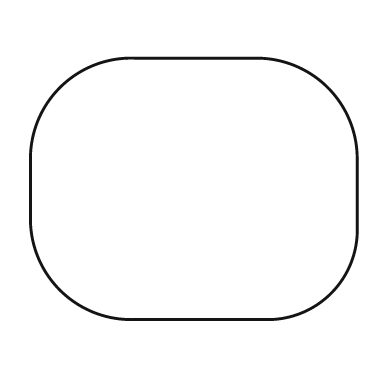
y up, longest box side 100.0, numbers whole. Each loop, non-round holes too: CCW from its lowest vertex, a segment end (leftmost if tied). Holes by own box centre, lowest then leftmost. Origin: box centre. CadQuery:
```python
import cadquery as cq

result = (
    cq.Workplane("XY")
    .moveTo(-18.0, -40.0)
    .lineTo(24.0, -40.0)
    .threePointArc((42.0, -32.0), (50.0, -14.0))
    .lineTo(50.0, 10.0)
    .threePointArc((41.0, 31.0), (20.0, 40.0))
    .lineTo(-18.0, 40.0)
    .threePointArc((-41.0, 31.0), (-50.0, 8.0))
    .lineTo(-50.0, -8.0)
    .threePointArc((-41.0, -31.0), (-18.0, -40.0))
    .close()
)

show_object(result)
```